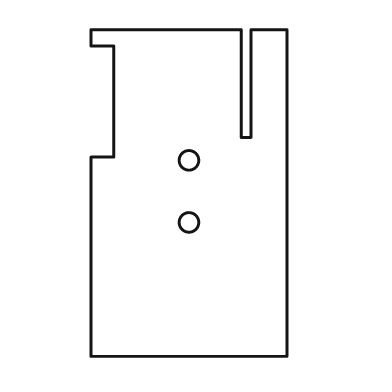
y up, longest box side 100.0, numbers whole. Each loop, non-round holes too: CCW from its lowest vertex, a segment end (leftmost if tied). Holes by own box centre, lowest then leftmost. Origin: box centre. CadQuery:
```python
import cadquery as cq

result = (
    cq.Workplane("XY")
    .moveTo(-30.0, -50.0)
    .lineTo(30.0, -50.0)
    .lineTo(30.0, 50.0)
    .lineTo(19.0, 50.0)
    .lineTo(19.0, 17.0)
    .lineTo(16.0, 17.0)
    .lineTo(16.0, 50.0)
    .lineTo(-30.0, 50.0)
    .lineTo(-30.0, 45.0)
    .lineTo(-23.0, 45.0)
    .lineTo(-23.0, 11.0)
    .lineTo(-30.0, 11.0)
    .close()
    .moveTo(0.0, -9.0)
    .circle(3.0)
    .moveTo(0.0, 10.0)
    .circle(3.0)
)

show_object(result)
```